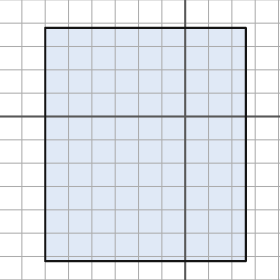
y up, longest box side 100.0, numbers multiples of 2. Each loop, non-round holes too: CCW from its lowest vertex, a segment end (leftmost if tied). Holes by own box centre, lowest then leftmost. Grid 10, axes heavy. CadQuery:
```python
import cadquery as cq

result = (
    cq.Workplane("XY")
    .moveTo(-60.0, -62.0)
    .lineTo(26.0, -62.0)
    .lineTo(26.0, 38.0)
    .lineTo(-60.0, 38.0)
    .close()
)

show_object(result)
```